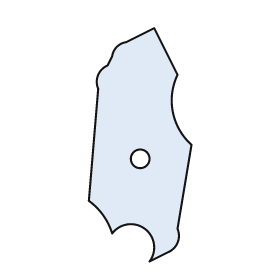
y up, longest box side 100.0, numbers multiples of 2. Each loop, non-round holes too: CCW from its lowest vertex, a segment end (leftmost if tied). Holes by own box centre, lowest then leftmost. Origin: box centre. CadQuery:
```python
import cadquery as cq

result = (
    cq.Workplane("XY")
    .moveTo(4.0, -50.0)
    .lineTo(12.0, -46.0)
    .threePointArc((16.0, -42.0), (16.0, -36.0))
    .lineTo(22.0, 0.0)
    .threePointArc((14.0, 14.0), (16.0, 30.0))
    .lineTo(6.0, 50.0)
    .lineTo(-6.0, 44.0)
    .threePointArc((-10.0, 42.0), (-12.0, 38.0))
    .lineTo(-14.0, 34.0)
    .threePointArc((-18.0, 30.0), (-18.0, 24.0))
    .lineTo(-22.0, -24.0)
    .threePointArc((-16.0, -30.0), (-12.0, -38.0))
    .threePointArc((2.0, -36.0), (4.0, -50.0))
    .close()
    .moveTo(0.0, -6.0)
    .circle(4.0)
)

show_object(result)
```